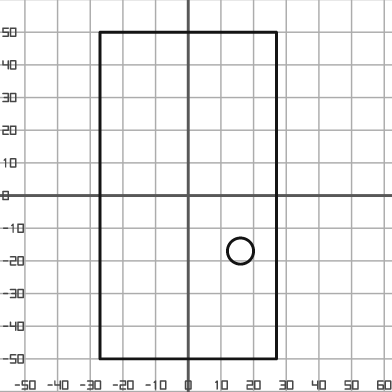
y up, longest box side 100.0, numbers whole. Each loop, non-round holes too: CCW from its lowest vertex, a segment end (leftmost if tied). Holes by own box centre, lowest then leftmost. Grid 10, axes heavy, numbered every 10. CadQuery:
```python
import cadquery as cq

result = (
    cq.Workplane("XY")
    .moveTo(-27.0, -50.0)
    .lineTo(27.0, -50.0)
    .lineTo(27.0, 50.0)
    .lineTo(-27.0, 50.0)
    .close()
    .moveTo(16.0, -17.0)
    .circle(4.0)
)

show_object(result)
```